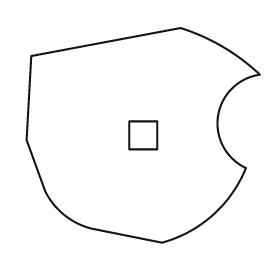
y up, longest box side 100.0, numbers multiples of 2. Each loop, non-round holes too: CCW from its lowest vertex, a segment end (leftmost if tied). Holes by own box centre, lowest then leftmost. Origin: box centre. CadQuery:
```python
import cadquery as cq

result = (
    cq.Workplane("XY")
    .moveTo(8.0, -46.0)
    .threePointArc((30.0, -34.0), (44.0, -14.0))
    .threePointArc((32.0, 8.0), (50.0, 26.0))
    .threePointArc((34.0, 38.0), (16.0, 46.0))
    .lineTo(-48.0, 34.0)
    .lineTo(-50.0, -2.0)
    .lineTo(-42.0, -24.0)
    .threePointArc((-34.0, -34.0), (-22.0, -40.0))
    .close()
    .moveTo(-6.0, -6.0)
    .lineTo(6.0, -6.0)
    .lineTo(6.0, 6.0)
    .lineTo(-6.0, 6.0)
    .close()
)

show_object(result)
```